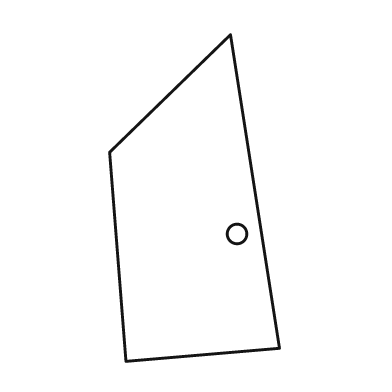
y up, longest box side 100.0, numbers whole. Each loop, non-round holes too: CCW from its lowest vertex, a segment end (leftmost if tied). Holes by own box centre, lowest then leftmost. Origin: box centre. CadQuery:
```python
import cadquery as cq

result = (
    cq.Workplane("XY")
    .moveTo(-21.0, -50.0)
    .lineTo(26.0, -46.0)
    .lineTo(11.0, 50.0)
    .lineTo(-26.0, 14.0)
    .close()
    .moveTo(13.0, -11.0)
    .circle(3.0)
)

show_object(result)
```